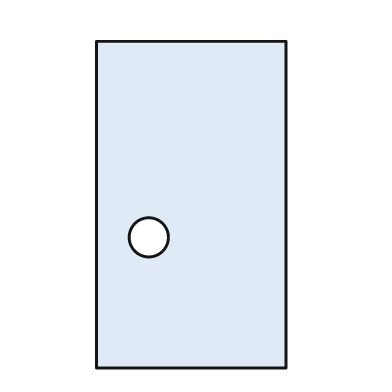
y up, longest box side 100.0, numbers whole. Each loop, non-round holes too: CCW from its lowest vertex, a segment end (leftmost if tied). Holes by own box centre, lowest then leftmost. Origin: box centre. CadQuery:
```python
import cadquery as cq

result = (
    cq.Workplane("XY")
    .moveTo(-29.0, -50.0)
    .lineTo(29.0, -50.0)
    .lineTo(29.0, 50.0)
    .lineTo(-29.0, 50.0)
    .close()
    .moveTo(-13.0, -10.0)
    .circle(6.0)
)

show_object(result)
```